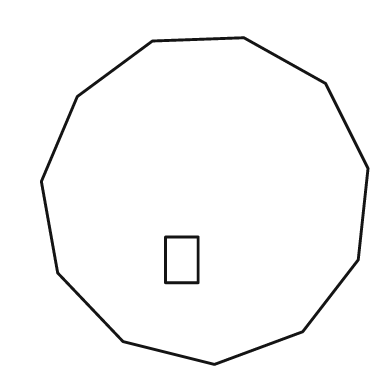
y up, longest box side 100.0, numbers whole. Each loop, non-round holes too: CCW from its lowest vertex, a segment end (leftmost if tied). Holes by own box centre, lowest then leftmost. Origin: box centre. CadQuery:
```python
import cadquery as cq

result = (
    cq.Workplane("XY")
    .moveTo(3.0, -50.0)
    .lineTo(30.0, -40.0)
    .lineTo(47.0, -18.0)
    .lineTo(50.0, 10.0)
    .lineTo(37.0, 36.0)
    .lineTo(12.0, 50.0)
    .lineTo(-16.0, 49.0)
    .lineTo(-39.0, 32.0)
    .lineTo(-50.0, 6.0)
    .lineTo(-45.0, -22.0)
    .lineTo(-25.0, -43.0)
    .close()
    .moveTo(-12.0, -25.0)
    .lineTo(-2.0, -25.0)
    .lineTo(-2.0, -11.0)
    .lineTo(-12.0, -11.0)
    .close()
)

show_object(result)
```